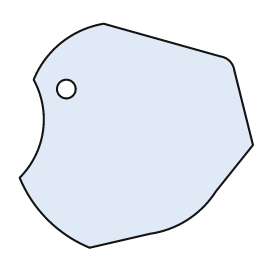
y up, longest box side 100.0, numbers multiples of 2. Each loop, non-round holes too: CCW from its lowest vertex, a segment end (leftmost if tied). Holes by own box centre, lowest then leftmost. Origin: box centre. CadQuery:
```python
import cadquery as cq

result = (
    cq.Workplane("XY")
    .moveTo(-20.0, -48.0)
    .lineTo(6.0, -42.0)
    .threePointArc((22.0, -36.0), (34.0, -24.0))
    .lineTo(50.0, -4.0)
    .lineTo(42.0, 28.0)
    .threePointArc((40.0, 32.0), (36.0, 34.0))
    .lineTo(-14.0, 48.0)
    .threePointArc((-32.0, 40.0), (-44.0, 24.0))
    .threePointArc((-40.0, 2.0), (-50.0, -18.0))
    .threePointArc((-38.0, -36.0), (-20.0, -48.0))
    .close()
    .moveTo(-30.0, 20.0)
    .circle(4.0)
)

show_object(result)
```